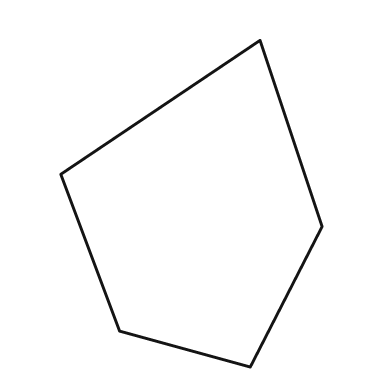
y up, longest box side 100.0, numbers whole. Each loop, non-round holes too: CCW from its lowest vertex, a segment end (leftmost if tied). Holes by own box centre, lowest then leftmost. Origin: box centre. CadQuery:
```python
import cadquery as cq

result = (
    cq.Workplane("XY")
    .moveTo(18.0, -50.0)
    .lineTo(40.0, -7.0)
    .lineTo(21.0, 50.0)
    .lineTo(-40.0, 9.0)
    .lineTo(-22.0, -39.0)
    .close()
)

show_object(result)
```